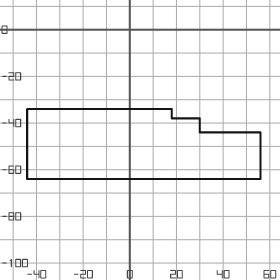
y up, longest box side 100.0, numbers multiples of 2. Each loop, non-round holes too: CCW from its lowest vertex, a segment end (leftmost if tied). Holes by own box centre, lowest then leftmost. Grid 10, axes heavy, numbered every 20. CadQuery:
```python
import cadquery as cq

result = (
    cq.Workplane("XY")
    .moveTo(-44.0, -64.0)
    .lineTo(56.0, -64.0)
    .lineTo(56.0, -44.0)
    .lineTo(30.0, -44.0)
    .lineTo(30.0, -38.0)
    .lineTo(18.0, -38.0)
    .lineTo(18.0, -34.0)
    .lineTo(-44.0, -34.0)
    .close()
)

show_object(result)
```